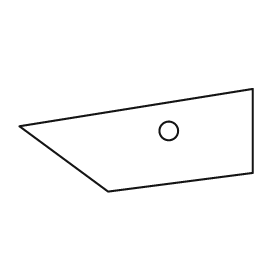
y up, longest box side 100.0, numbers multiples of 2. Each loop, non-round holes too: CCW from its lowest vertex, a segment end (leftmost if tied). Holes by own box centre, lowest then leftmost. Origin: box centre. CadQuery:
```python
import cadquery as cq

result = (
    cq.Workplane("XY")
    .moveTo(-12.0, -22.0)
    .lineTo(50.0, -14.0)
    .lineTo(50.0, 22.0)
    .lineTo(-50.0, 6.0)
    .close()
    .moveTo(14.0, 4.0)
    .circle(4.0)
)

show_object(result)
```